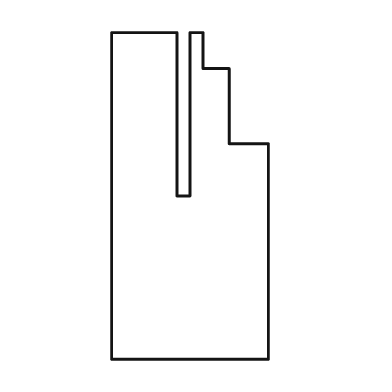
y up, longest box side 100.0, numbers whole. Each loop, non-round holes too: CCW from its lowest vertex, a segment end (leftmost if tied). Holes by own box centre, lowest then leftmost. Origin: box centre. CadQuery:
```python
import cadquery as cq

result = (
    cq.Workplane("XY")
    .moveTo(-24.0, -50.0)
    .lineTo(24.0, -50.0)
    .lineTo(24.0, 16.0)
    .lineTo(12.0, 16.0)
    .lineTo(12.0, 39.0)
    .lineTo(4.0, 39.0)
    .lineTo(4.0, 50.0)
    .lineTo(0.0, 50.0)
    .lineTo(0.0, 0.0)
    .lineTo(-4.0, 0.0)
    .lineTo(-4.0, 50.0)
    .lineTo(-24.0, 50.0)
    .close()
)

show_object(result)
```